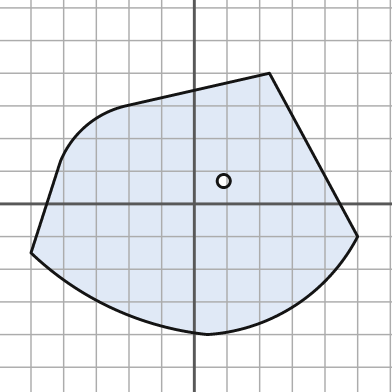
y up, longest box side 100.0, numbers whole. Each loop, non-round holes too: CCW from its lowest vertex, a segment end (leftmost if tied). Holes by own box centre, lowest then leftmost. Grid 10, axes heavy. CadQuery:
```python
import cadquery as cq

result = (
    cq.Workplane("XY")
    .moveTo(4.0, -40.0)
    .threePointArc((31.0, -31.0), (50.0, -10.0))
    .lineTo(23.0, 40.0)
    .lineTo(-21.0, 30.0)
    .threePointArc((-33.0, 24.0), (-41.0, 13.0))
    .lineTo(-50.0, -15.0)
    .threePointArc((-25.0, -32.0), (4.0, -40.0))
    .close()
    .moveTo(9.0, 7.0)
    .circle(2.0)
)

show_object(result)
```